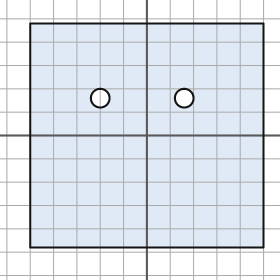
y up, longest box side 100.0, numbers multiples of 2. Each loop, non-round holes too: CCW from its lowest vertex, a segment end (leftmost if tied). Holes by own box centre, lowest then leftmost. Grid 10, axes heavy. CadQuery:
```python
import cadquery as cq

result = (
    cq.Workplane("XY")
    .moveTo(-50.0, -48.0)
    .lineTo(50.0, -48.0)
    .lineTo(50.0, 48.0)
    .lineTo(-50.0, 48.0)
    .close()
    .moveTo(-20.0, 16.0)
    .circle(4.0)
    .moveTo(16.0, 16.0)
    .circle(4.0)
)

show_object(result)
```